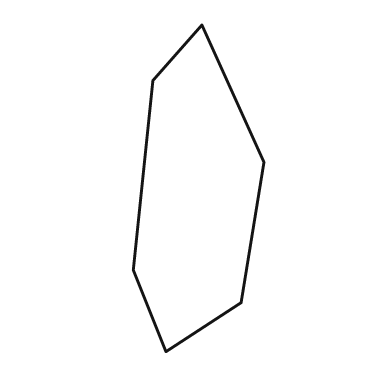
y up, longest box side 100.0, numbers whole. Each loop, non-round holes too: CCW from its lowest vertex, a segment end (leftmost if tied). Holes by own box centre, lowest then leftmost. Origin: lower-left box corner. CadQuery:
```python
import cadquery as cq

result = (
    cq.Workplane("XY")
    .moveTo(10.0, 0.0)
    .lineTo(33.0, 15.0)
    .lineTo(40.0, 58.0)
    .lineTo(21.0, 100.0)
    .lineTo(6.0, 83.0)
    .lineTo(0.0, 25.0)
    .close()
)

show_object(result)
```